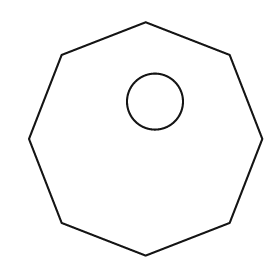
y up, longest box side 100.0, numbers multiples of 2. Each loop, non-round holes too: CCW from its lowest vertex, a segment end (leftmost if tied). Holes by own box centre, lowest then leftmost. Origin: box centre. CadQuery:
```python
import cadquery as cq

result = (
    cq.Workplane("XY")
    .moveTo(0.0, -50.0)
    .lineTo(36.0, -36.0)
    .lineTo(50.0, 0.0)
    .lineTo(36.0, 36.0)
    .lineTo(0.0, 50.0)
    .lineTo(-36.0, 36.0)
    .lineTo(-50.0, 0.0)
    .lineTo(-36.0, -36.0)
    .close()
    .moveTo(4.0, 16.0)
    .circle(12.0)
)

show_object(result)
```